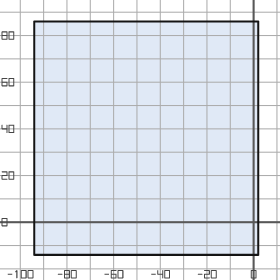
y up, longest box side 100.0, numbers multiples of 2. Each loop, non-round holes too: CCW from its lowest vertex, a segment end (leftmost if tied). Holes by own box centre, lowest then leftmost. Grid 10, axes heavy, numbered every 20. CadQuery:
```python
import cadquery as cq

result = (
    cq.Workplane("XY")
    .moveTo(-94.0, -14.0)
    .lineTo(2.0, -14.0)
    .lineTo(2.0, 86.0)
    .lineTo(-94.0, 86.0)
    .close()
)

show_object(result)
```